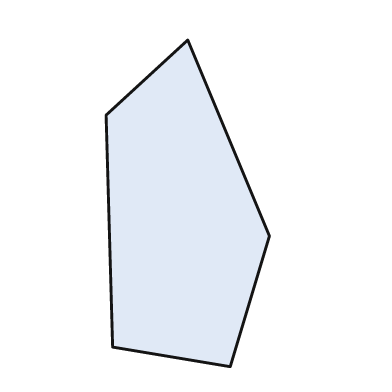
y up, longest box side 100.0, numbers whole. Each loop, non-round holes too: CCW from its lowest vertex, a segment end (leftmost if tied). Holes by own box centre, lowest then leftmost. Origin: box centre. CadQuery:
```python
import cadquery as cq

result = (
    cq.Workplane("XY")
    .moveTo(13.0, -50.0)
    .lineTo(25.0, -10.0)
    .lineTo(0.0, 50.0)
    .lineTo(-25.0, 27.0)
    .lineTo(-23.0, -44.0)
    .close()
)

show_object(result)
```